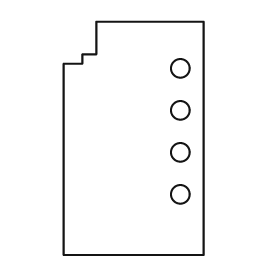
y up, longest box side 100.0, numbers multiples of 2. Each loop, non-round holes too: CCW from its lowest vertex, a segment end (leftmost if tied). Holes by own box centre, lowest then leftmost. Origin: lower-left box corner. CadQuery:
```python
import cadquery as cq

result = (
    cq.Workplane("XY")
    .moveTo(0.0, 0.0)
    .lineTo(60.0, 0.0)
    .lineTo(60.0, 100.0)
    .lineTo(14.0, 100.0)
    .lineTo(14.0, 86.0)
    .lineTo(8.0, 86.0)
    .lineTo(8.0, 82.0)
    .lineTo(0.0, 82.0)
    .close()
    .moveTo(50.0, 26.0)
    .circle(4.0)
    .moveTo(50.0, 44.0)
    .circle(4.0)
    .moveTo(50.0, 62.0)
    .circle(4.0)
    .moveTo(50.0, 80.0)
    .circle(4.0)
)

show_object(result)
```